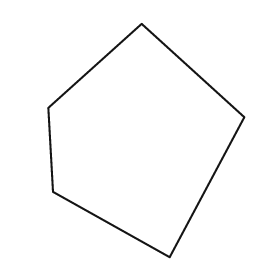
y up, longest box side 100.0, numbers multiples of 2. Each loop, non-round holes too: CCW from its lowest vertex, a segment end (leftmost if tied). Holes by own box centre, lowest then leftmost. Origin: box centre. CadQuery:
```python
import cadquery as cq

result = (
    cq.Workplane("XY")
    .moveTo(10.0, -50.0)
    .lineTo(42.0, 10.0)
    .lineTo(-2.0, 50.0)
    .lineTo(-42.0, 14.0)
    .lineTo(-40.0, -22.0)
    .close()
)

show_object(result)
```